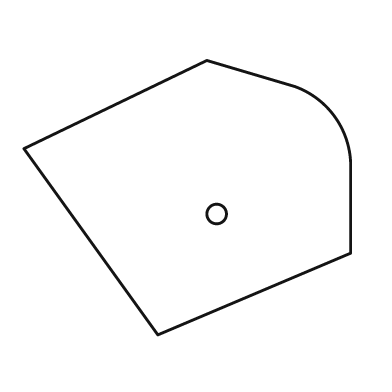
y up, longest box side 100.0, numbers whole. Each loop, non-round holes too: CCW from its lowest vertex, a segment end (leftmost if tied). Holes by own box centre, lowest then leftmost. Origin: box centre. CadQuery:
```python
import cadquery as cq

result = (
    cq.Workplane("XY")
    .moveTo(-9.0, -42.0)
    .lineTo(50.0, -17.0)
    .lineTo(50.0, 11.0)
    .threePointArc((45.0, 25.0), (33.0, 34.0))
    .lineTo(6.0, 42.0)
    .lineTo(-50.0, 15.0)
    .close()
    .moveTo(9.0, -5.0)
    .circle(3.0)
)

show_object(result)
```